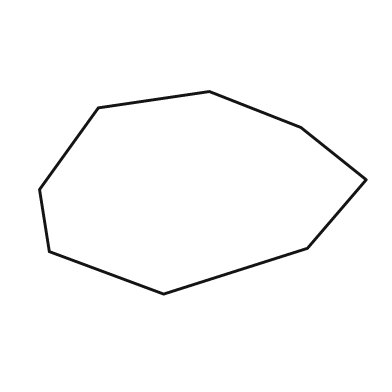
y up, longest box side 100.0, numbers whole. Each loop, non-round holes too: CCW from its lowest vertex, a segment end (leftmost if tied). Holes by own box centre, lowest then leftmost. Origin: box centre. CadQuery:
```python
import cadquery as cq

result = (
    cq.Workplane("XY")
    .moveTo(-12.0, -31.0)
    .lineTo(32.0, -17.0)
    .lineTo(50.0, 4.0)
    .lineTo(30.0, 20.0)
    .lineTo(2.0, 31.0)
    .lineTo(-32.0, 26.0)
    .lineTo(-50.0, 1.0)
    .lineTo(-47.0, -18.0)
    .close()
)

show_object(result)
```